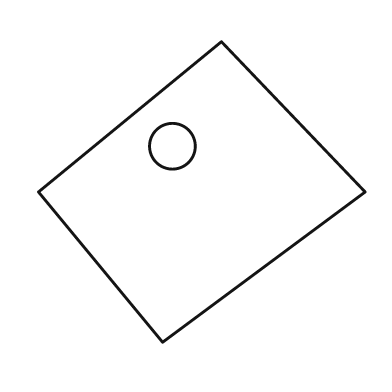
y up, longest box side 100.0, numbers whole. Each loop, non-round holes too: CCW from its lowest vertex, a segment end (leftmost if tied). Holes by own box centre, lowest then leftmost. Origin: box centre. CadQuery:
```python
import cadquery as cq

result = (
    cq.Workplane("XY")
    .moveTo(-12.0, -46.0)
    .lineTo(50.0, 0.0)
    .lineTo(6.0, 46.0)
    .lineTo(-50.0, 0.0)
    .close()
    .moveTo(-9.0, 14.0)
    .circle(7.0)
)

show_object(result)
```